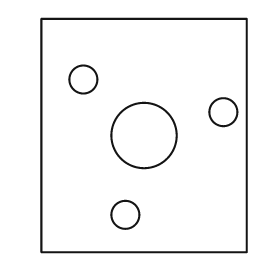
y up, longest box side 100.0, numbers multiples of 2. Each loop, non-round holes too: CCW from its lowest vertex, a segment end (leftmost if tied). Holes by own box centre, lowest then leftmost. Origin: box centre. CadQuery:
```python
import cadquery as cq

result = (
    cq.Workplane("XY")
    .moveTo(-44.0, -50.0)
    .lineTo(44.0, -50.0)
    .lineTo(44.0, 50.0)
    .lineTo(-44.0, 50.0)
    .close()
    .moveTo(-8.0, -34.0)
    .circle(6.0)
    .moveTo(0.0, 0.0)
    .circle(14.0)
    .moveTo(34.0, 10.0)
    .circle(6.0)
    .moveTo(-26.0, 24.0)
    .circle(6.0)
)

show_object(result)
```